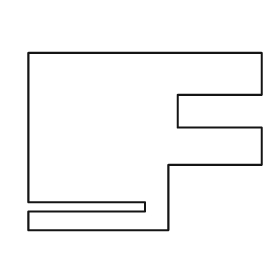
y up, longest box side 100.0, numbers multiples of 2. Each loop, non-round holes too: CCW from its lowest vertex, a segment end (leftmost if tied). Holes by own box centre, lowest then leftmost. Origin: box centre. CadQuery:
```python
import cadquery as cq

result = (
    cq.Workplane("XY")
    .moveTo(-50.0, -38.0)
    .lineTo(10.0, -38.0)
    .lineTo(10.0, -10.0)
    .lineTo(50.0, -10.0)
    .lineTo(50.0, 6.0)
    .lineTo(14.0, 6.0)
    .lineTo(14.0, 20.0)
    .lineTo(50.0, 20.0)
    .lineTo(50.0, 38.0)
    .lineTo(-50.0, 38.0)
    .lineTo(-50.0, -26.0)
    .lineTo(0.0, -26.0)
    .lineTo(0.0, -30.0)
    .lineTo(-50.0, -30.0)
    .close()
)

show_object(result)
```